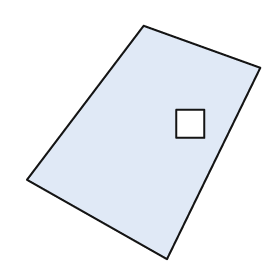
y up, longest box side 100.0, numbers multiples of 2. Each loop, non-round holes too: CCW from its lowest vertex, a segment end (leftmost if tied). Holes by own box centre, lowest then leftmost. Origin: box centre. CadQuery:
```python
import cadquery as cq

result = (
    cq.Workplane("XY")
    .moveTo(10.0, -50.0)
    .lineTo(50.0, 32.0)
    .lineTo(0.0, 50.0)
    .lineTo(-50.0, -16.0)
    .close()
    .moveTo(14.0, 2.0)
    .lineTo(26.0, 2.0)
    .lineTo(26.0, 14.0)
    .lineTo(14.0, 14.0)
    .close()
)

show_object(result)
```